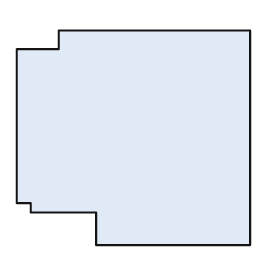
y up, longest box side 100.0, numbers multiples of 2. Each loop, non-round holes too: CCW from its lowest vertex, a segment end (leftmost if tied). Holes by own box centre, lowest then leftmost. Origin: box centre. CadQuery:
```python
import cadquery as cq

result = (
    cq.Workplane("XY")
    .moveTo(-16.0, -46.0)
    .lineTo(50.0, -46.0)
    .lineTo(50.0, 46.0)
    .lineTo(-32.0, 46.0)
    .lineTo(-32.0, 38.0)
    .lineTo(-50.0, 38.0)
    .lineTo(-50.0, -28.0)
    .lineTo(-44.0, -28.0)
    .lineTo(-44.0, -32.0)
    .lineTo(-16.0, -32.0)
    .close()
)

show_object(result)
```